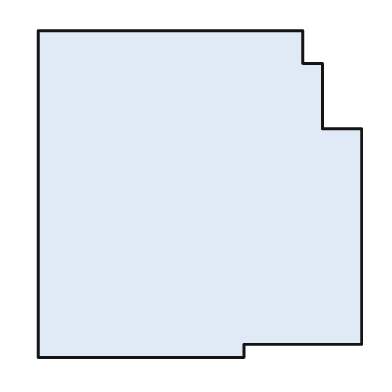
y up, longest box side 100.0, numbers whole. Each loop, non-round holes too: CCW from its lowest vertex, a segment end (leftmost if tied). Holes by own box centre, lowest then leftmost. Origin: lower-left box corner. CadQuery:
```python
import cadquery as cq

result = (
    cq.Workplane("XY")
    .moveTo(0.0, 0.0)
    .lineTo(63.0, 0.0)
    .lineTo(63.0, 4.0)
    .lineTo(99.0, 4.0)
    .lineTo(99.0, 70.0)
    .lineTo(87.0, 70.0)
    .lineTo(87.0, 90.0)
    .lineTo(81.0, 90.0)
    .lineTo(81.0, 100.0)
    .lineTo(0.0, 100.0)
    .close()
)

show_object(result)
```